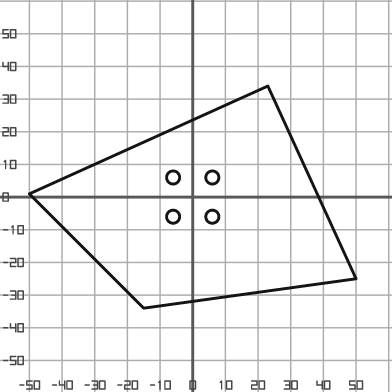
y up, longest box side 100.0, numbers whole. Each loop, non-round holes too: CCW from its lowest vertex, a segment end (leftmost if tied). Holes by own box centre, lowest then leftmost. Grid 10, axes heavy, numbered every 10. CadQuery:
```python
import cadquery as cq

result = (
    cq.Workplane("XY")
    .moveTo(-15.0, -34.0)
    .lineTo(50.0, -25.0)
    .lineTo(23.0, 34.0)
    .lineTo(-50.0, 1.0)
    .close()
    .moveTo(-6.0, -6.0)
    .circle(2.0)
    .moveTo(6.0, -6.0)
    .circle(2.0)
    .moveTo(-6.0, 6.0)
    .circle(2.0)
    .moveTo(6.0, 6.0)
    .circle(2.0)
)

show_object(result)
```